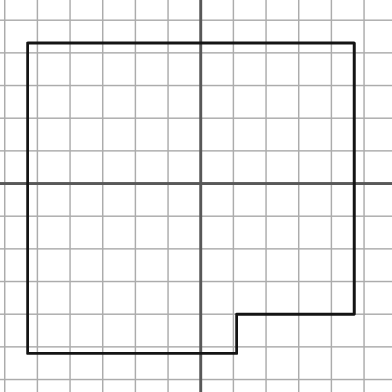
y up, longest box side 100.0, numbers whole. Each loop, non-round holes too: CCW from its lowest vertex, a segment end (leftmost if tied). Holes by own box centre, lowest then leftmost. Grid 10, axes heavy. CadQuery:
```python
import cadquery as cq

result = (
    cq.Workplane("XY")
    .moveTo(-53.0, -52.0)
    .lineTo(11.0, -52.0)
    .lineTo(11.0, -40.0)
    .lineTo(47.0, -40.0)
    .lineTo(47.0, 43.0)
    .lineTo(-53.0, 43.0)
    .close()
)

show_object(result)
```